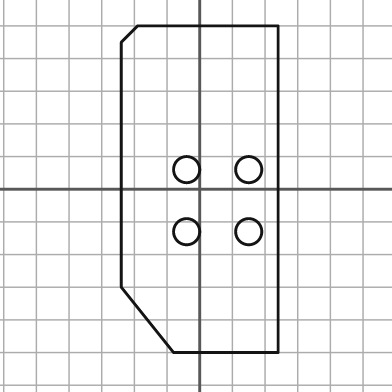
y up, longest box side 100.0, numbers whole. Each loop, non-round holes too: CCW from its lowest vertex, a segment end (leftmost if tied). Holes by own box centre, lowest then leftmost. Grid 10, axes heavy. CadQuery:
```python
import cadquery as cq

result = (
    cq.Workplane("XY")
    .moveTo(-8.0, -50.0)
    .lineTo(24.0, -50.0)
    .lineTo(24.0, 50.0)
    .lineTo(-19.0, 50.0)
    .lineTo(-24.0, 45.0)
    .lineTo(-24.0, -30.0)
    .close()
    .moveTo(-4.0, -13.0)
    .circle(4.0)
    .moveTo(15.0, -13.0)
    .circle(4.0)
    .moveTo(-4.0, 6.0)
    .circle(4.0)
    .moveTo(15.0, 6.0)
    .circle(4.0)
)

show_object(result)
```